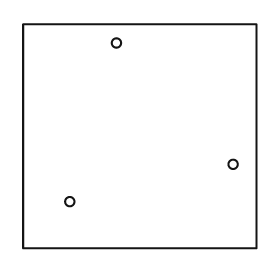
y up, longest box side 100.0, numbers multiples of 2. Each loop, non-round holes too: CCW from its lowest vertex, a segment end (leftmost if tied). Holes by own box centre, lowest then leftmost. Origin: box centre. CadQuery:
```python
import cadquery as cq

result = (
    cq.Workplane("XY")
    .moveTo(-50.0, -48.0)
    .lineTo(50.0, -48.0)
    .lineTo(50.0, 48.0)
    .lineTo(-50.0, 48.0)
    .close()
    .moveTo(-30.0, -28.0)
    .circle(2.0)
    .moveTo(40.0, -12.0)
    .circle(2.0)
    .moveTo(-10.0, 40.0)
    .circle(2.0)
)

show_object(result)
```